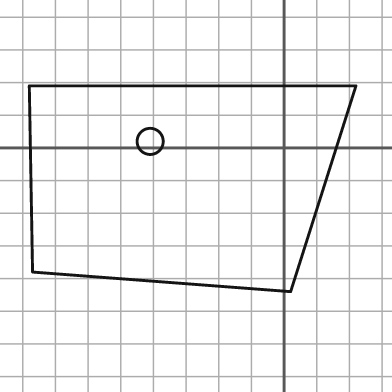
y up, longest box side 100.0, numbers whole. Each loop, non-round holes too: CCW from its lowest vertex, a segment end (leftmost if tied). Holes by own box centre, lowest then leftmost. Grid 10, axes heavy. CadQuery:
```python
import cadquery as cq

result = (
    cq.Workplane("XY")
    .moveTo(2.0, -44.0)
    .lineTo(22.0, 19.0)
    .lineTo(-78.0, 19.0)
    .lineTo(-77.0, -38.0)
    .close()
    .moveTo(-41.0, 2.0)
    .circle(4.0)
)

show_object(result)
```